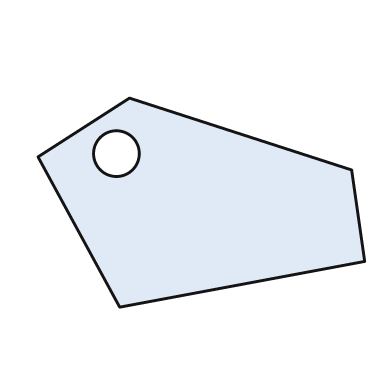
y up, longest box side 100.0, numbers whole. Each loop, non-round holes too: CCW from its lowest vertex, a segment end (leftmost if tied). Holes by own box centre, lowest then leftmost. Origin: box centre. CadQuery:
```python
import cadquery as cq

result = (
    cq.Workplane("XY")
    .moveTo(-25.0, -32.0)
    .lineTo(50.0, -18.0)
    .lineTo(46.0, 10.0)
    .lineTo(-22.0, 32.0)
    .lineTo(-50.0, 14.0)
    .close()
    .moveTo(-26.0, 15.0)
    .circle(7.0)
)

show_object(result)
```